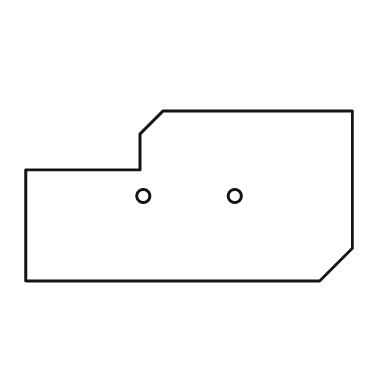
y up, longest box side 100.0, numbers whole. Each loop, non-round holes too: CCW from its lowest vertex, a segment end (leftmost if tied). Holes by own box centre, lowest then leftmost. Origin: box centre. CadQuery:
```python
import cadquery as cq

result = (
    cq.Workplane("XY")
    .moveTo(-50.0, -26.0)
    .lineTo(40.0, -26.0)
    .lineTo(50.0, -16.0)
    .lineTo(50.0, 26.0)
    .lineTo(-8.0, 26.0)
    .lineTo(-15.0, 19.0)
    .lineTo(-15.0, 8.0)
    .lineTo(-50.0, 8.0)
    .close()
    .moveTo(-14.0, 0.0)
    .circle(2.0)
    .moveTo(14.0, 0.0)
    .circle(2.0)
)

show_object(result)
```